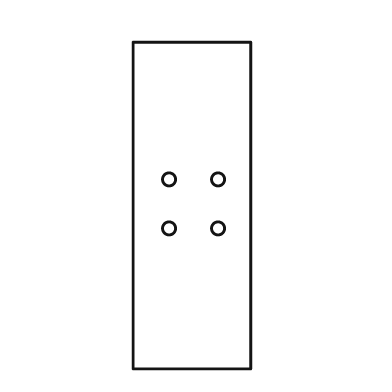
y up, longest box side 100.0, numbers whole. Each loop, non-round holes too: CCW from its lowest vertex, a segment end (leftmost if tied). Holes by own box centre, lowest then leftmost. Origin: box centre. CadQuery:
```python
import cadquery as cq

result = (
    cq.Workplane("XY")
    .moveTo(-18.0, -50.0)
    .lineTo(18.0, -50.0)
    .lineTo(18.0, 50.0)
    .lineTo(-18.0, 50.0)
    .close()
    .moveTo(-7.0, -7.0)
    .circle(2.0)
    .moveTo(8.0, -7.0)
    .circle(2.0)
    .moveTo(-7.0, 8.0)
    .circle(2.0)
    .moveTo(8.0, 8.0)
    .circle(2.0)
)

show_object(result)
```